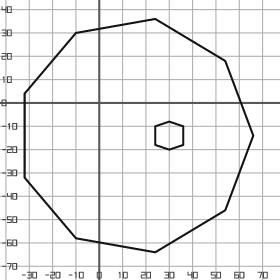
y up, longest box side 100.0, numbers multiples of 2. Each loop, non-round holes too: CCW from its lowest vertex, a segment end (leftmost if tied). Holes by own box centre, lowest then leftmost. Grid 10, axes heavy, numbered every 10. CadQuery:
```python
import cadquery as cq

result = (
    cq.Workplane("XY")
    .moveTo(24.0, -64.0)
    .lineTo(54.0, -46.0)
    .lineTo(66.0, -14.0)
    .lineTo(54.0, 18.0)
    .lineTo(24.0, 36.0)
    .lineTo(-10.0, 30.0)
    .lineTo(-32.0, 4.0)
    .lineTo(-32.0, -32.0)
    .lineTo(-10.0, -58.0)
    .close()
    .moveTo(30.0, -20.0)
    .lineTo(36.0, -18.0)
    .lineTo(36.0, -10.0)
    .lineTo(30.0, -8.0)
    .lineTo(24.0, -10.0)
    .lineTo(24.0, -18.0)
    .close()
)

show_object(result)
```